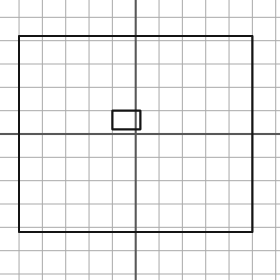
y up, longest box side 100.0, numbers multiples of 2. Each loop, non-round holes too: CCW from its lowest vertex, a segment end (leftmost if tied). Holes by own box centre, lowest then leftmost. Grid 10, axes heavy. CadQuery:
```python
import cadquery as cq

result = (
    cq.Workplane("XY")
    .moveTo(-50.0, -42.0)
    .lineTo(50.0, -42.0)
    .lineTo(50.0, 42.0)
    .lineTo(-50.0, 42.0)
    .close()
    .moveTo(-10.0, 2.0)
    .lineTo(2.0, 2.0)
    .lineTo(2.0, 10.0)
    .lineTo(-10.0, 10.0)
    .close()
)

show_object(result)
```